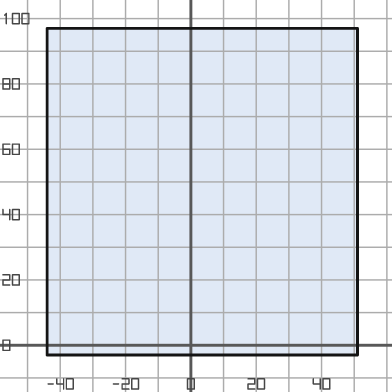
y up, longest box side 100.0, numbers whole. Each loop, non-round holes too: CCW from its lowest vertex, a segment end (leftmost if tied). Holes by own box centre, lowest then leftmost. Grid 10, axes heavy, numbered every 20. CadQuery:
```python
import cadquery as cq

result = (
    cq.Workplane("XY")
    .moveTo(-44.0, -3.0)
    .lineTo(51.0, -3.0)
    .lineTo(51.0, 97.0)
    .lineTo(-44.0, 97.0)
    .close()
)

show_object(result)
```